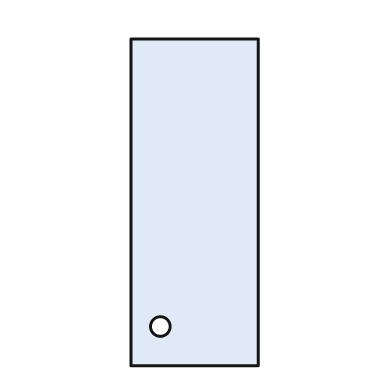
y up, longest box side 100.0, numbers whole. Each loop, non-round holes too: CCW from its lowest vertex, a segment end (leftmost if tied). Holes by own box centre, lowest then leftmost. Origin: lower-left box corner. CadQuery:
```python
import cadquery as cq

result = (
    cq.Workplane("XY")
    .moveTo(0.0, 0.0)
    .lineTo(39.0, 0.0)
    .lineTo(39.0, 100.0)
    .lineTo(0.0, 100.0)
    .close()
    .moveTo(9.0, 12.0)
    .circle(3.0)
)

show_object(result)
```